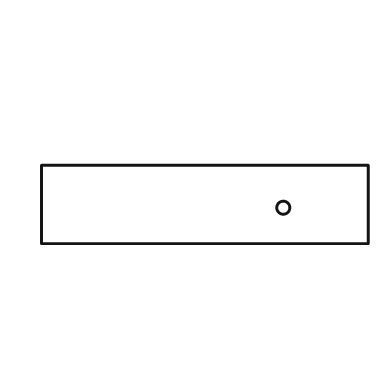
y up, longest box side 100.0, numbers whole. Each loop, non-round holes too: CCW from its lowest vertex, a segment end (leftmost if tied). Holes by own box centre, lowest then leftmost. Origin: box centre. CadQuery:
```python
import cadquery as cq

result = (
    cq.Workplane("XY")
    .moveTo(-50.0, -12.0)
    .lineTo(50.0, -12.0)
    .lineTo(50.0, 12.0)
    .lineTo(-50.0, 12.0)
    .close()
    .moveTo(24.0, -1.0)
    .circle(2.0)
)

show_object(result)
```